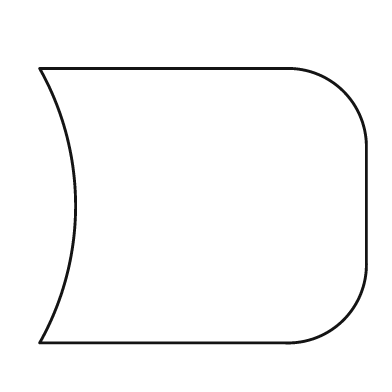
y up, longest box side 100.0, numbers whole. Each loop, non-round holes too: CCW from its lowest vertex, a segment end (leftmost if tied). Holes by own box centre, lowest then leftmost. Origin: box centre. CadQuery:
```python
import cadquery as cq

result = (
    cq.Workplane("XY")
    .moveTo(-50.0, -42.0)
    .lineTo(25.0, -42.0)
    .threePointArc((43.0, -35.0), (50.0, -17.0))
    .lineTo(50.0, 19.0)
    .threePointArc((43.0, 35.0), (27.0, 42.0))
    .lineTo(-50.0, 42.0)
    .threePointArc((-39.0, 0.0), (-50.0, -42.0))
    .close()
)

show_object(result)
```